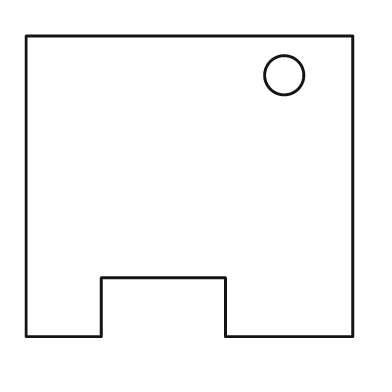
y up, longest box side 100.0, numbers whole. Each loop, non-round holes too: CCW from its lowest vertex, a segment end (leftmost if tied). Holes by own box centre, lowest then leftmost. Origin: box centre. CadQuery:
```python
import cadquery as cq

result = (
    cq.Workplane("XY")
    .moveTo(-50.0, -46.0)
    .lineTo(-27.0, -46.0)
    .lineTo(-27.0, -28.0)
    .lineTo(11.0, -28.0)
    .lineTo(11.0, -46.0)
    .lineTo(50.0, -46.0)
    .lineTo(50.0, 46.0)
    .lineTo(-50.0, 46.0)
    .close()
    .moveTo(29.0, 34.0)
    .circle(6.0)
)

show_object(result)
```